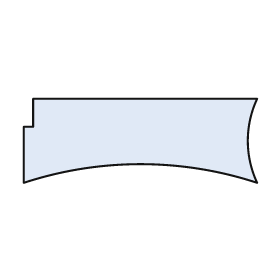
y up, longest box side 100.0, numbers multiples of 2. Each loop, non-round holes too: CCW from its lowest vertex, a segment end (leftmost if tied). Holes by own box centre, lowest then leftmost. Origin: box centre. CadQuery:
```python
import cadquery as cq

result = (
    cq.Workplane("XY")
    .moveTo(-50.0, -18.0)
    .threePointArc((0.0, -10.0), (50.0, -18.0))
    .threePointArc((46.0, 0.0), (50.0, 18.0))
    .lineTo(-46.0, 18.0)
    .lineTo(-46.0, 6.0)
    .lineTo(-50.0, 6.0)
    .close()
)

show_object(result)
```